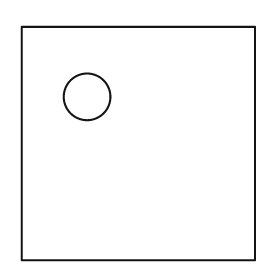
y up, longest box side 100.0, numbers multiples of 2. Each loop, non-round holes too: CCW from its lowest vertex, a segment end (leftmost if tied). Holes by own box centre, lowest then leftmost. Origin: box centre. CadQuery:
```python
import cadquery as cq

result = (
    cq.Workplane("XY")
    .moveTo(-50.0, -50.0)
    .lineTo(50.0, -50.0)
    .lineTo(50.0, 50.0)
    .lineTo(-50.0, 50.0)
    .close()
    .moveTo(-22.0, 20.0)
    .circle(10.0)
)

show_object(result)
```